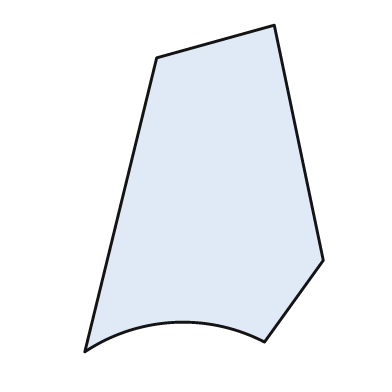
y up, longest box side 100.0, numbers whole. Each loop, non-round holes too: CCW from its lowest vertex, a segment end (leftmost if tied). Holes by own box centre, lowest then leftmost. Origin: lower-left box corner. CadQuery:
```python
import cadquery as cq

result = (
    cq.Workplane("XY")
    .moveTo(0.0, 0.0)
    .threePointArc((27.0, 9.0), (55.0, 3.0))
    .lineTo(73.0, 28.0)
    .lineTo(58.0, 100.0)
    .lineTo(22.0, 90.0)
    .close()
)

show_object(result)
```